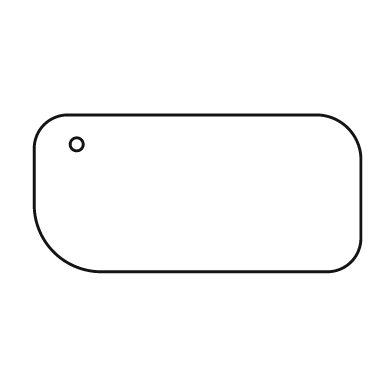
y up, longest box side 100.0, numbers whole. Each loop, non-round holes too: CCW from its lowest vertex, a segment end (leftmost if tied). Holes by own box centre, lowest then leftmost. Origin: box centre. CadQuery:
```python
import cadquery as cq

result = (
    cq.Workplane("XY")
    .moveTo(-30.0, -24.0)
    .lineTo(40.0, -24.0)
    .threePointArc((47.0, -21.0), (50.0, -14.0))
    .lineTo(50.0, 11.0)
    .threePointArc((46.0, 20.0), (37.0, 24.0))
    .lineTo(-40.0, 24.0)
    .threePointArc((-47.0, 21.0), (-50.0, 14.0))
    .lineTo(-50.0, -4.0)
    .threePointArc((-44.0, -18.0), (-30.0, -24.0))
    .close()
    .moveTo(-37.0, 15.0)
    .circle(2.0)
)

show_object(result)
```